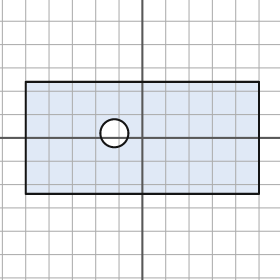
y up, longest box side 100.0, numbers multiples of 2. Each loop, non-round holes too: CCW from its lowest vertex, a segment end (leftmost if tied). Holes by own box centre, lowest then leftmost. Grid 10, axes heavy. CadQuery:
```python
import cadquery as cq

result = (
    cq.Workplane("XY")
    .moveTo(-50.0, -24.0)
    .lineTo(50.0, -24.0)
    .lineTo(50.0, 24.0)
    .lineTo(-50.0, 24.0)
    .close()
    .moveTo(-12.0, 2.0)
    .circle(6.0)
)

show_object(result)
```